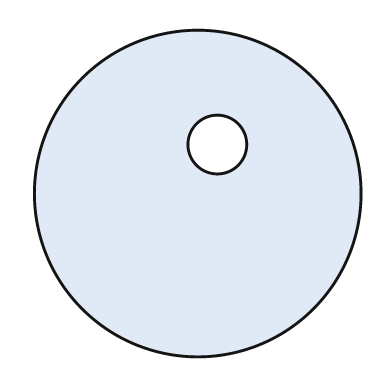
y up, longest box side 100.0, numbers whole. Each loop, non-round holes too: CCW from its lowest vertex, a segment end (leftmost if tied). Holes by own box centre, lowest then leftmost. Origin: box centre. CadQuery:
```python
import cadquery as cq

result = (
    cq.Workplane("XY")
    .moveTo(0.0, 0.0)
    .circle(50.0)
    .moveTo(6.0, 15.0)
    .circle(9.0)
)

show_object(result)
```